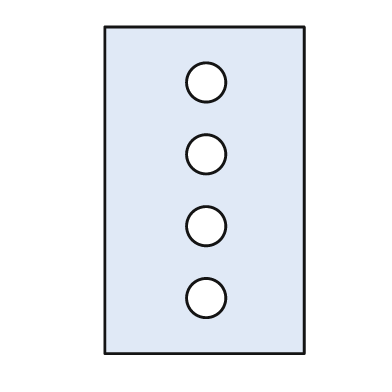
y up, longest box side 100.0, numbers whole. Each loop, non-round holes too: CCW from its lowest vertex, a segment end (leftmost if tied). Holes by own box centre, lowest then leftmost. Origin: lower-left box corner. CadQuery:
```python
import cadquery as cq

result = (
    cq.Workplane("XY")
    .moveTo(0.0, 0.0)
    .lineTo(61.0, 0.0)
    .lineTo(61.0, 100.0)
    .lineTo(0.0, 100.0)
    .close()
    .moveTo(31.0, 17.0)
    .circle(6.0)
    .moveTo(31.0, 39.0)
    .circle(6.0)
    .moveTo(31.0, 61.0)
    .circle(6.0)
    .moveTo(31.0, 83.0)
    .circle(6.0)
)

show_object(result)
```